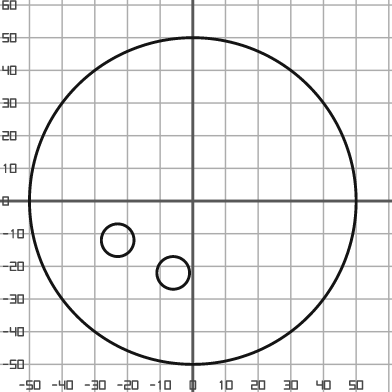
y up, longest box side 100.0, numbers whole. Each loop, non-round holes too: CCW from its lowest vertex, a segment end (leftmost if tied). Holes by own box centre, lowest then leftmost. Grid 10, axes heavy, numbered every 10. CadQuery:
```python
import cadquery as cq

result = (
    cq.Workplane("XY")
    .moveTo(0.0, 0.0)
    .circle(50.0)
    .moveTo(-6.0, -22.0)
    .circle(5.0)
    .moveTo(-23.0, -12.0)
    .circle(5.0)
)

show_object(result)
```